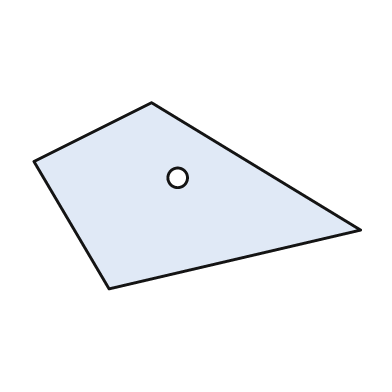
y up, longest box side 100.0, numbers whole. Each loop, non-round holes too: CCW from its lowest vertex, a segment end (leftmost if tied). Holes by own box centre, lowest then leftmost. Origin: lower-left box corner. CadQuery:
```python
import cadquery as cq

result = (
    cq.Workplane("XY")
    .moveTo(23.0, 0.0)
    .lineTo(100.0, 18.0)
    .lineTo(36.0, 57.0)
    .lineTo(0.0, 39.0)
    .close()
    .moveTo(44.0, 34.0)
    .circle(3.0)
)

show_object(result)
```